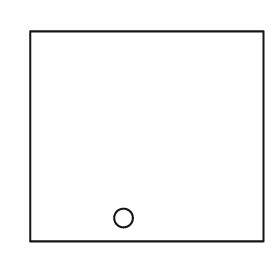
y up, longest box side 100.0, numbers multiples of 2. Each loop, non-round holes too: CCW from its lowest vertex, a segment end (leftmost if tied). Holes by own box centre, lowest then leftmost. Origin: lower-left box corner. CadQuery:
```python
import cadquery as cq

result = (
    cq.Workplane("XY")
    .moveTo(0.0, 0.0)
    .lineTo(100.0, 0.0)
    .lineTo(100.0, 90.0)
    .lineTo(0.0, 90.0)
    .close()
    .moveTo(40.0, 10.0)
    .circle(4.0)
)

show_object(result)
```